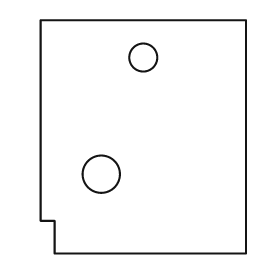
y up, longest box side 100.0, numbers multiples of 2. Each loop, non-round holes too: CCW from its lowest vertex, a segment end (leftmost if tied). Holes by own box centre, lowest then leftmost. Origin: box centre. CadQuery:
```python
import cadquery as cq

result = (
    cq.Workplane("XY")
    .moveTo(-38.0, -50.0)
    .lineTo(44.0, -50.0)
    .lineTo(44.0, 50.0)
    .lineTo(-44.0, 50.0)
    .lineTo(-44.0, -36.0)
    .lineTo(-38.0, -36.0)
    .close()
    .moveTo(-18.0, -16.0)
    .circle(8.0)
    .moveTo(0.0, 34.0)
    .circle(6.0)
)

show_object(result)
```